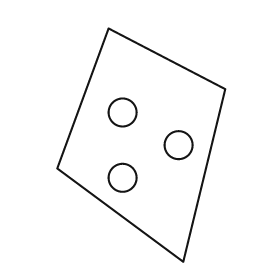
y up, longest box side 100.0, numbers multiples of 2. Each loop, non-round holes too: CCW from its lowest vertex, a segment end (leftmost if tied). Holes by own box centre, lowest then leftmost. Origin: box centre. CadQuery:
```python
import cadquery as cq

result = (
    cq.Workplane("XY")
    .moveTo(18.0, -50.0)
    .lineTo(36.0, 24.0)
    .lineTo(-14.0, 50.0)
    .lineTo(-36.0, -10.0)
    .close()
    .moveTo(-8.0, -14.0)
    .circle(6.0)
    .moveTo(16.0, 0.0)
    .circle(6.0)
    .moveTo(-8.0, 14.0)
    .circle(6.0)
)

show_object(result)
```